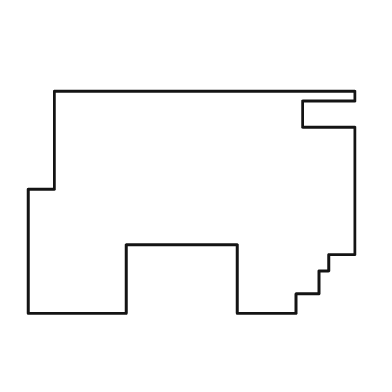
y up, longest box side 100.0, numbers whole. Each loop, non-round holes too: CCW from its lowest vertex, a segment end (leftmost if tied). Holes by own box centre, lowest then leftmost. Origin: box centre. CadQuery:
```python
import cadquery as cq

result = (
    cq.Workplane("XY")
    .moveTo(-50.0, -34.0)
    .lineTo(-20.0, -34.0)
    .lineTo(-20.0, -13.0)
    .lineTo(14.0, -13.0)
    .lineTo(14.0, -34.0)
    .lineTo(32.0, -34.0)
    .lineTo(32.0, -28.0)
    .lineTo(39.0, -28.0)
    .lineTo(39.0, -21.0)
    .lineTo(42.0, -21.0)
    .lineTo(42.0, -16.0)
    .lineTo(50.0, -16.0)
    .lineTo(50.0, 23.0)
    .lineTo(34.0, 23.0)
    .lineTo(34.0, 31.0)
    .lineTo(50.0, 31.0)
    .lineTo(50.0, 34.0)
    .lineTo(-42.0, 34.0)
    .lineTo(-42.0, 4.0)
    .lineTo(-50.0, 4.0)
    .close()
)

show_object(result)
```